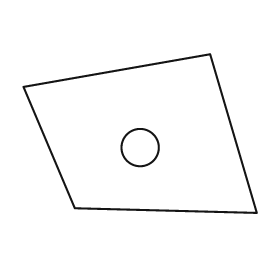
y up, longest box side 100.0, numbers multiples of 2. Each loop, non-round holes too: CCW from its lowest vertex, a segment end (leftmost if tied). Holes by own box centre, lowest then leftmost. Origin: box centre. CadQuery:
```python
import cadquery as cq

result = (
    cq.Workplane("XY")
    .moveTo(50.0, -34.0)
    .lineTo(30.0, 34.0)
    .lineTo(-50.0, 20.0)
    .lineTo(-28.0, -32.0)
    .close()
    .moveTo(0.0, -6.0)
    .circle(8.0)
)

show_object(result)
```